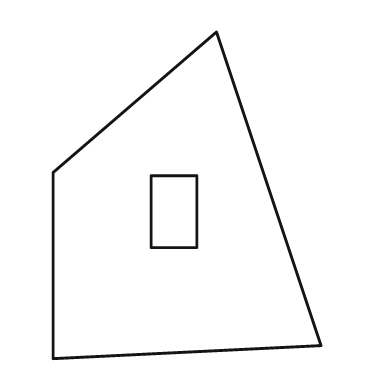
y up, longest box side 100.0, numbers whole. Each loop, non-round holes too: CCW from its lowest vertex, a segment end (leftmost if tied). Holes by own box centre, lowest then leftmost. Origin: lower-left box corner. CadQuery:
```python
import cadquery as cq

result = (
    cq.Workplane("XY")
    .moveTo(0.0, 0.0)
    .lineTo(82.0, 4.0)
    .lineTo(50.0, 100.0)
    .lineTo(0.0, 57.0)
    .close()
    .moveTo(30.0, 34.0)
    .lineTo(44.0, 34.0)
    .lineTo(44.0, 56.0)
    .lineTo(30.0, 56.0)
    .close()
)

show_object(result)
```